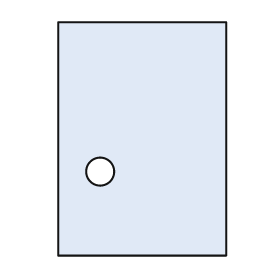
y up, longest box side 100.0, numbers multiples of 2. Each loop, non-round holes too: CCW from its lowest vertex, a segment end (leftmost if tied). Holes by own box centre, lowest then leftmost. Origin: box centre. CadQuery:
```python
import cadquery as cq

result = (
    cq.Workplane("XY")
    .moveTo(-36.0, -50.0)
    .lineTo(36.0, -50.0)
    .lineTo(36.0, 50.0)
    .lineTo(-36.0, 50.0)
    .close()
    .moveTo(-18.0, -14.0)
    .circle(6.0)
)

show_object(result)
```